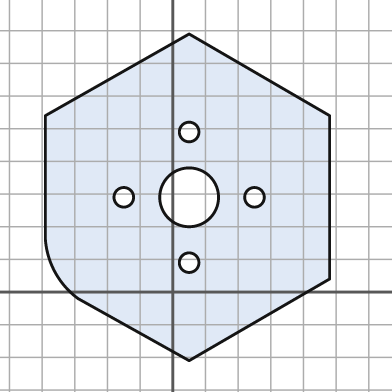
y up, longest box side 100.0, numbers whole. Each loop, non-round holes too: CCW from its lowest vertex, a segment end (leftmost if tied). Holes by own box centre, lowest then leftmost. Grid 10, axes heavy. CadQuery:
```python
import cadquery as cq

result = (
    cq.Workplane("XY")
    .moveTo(5.0, -21.0)
    .lineTo(48.0, 4.0)
    .lineTo(48.0, 54.0)
    .lineTo(5.0, 79.0)
    .lineTo(-39.0, 54.0)
    .lineTo(-39.0, 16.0)
    .threePointArc((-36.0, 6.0), (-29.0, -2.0))
    .close()
    .moveTo(5.0, 9.0)
    .circle(3.0)
    .moveTo(-15.0, 29.0)
    .circle(3.0)
    .moveTo(5.0, 29.0)
    .circle(9.0)
    .moveTo(25.0, 29.0)
    .circle(3.0)
    .moveTo(5.0, 49.0)
    .circle(3.0)
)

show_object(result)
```